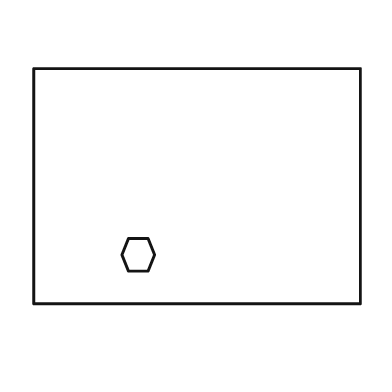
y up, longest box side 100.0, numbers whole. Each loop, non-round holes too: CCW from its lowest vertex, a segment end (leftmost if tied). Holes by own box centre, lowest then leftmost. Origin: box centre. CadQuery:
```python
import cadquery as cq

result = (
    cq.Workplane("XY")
    .moveTo(-50.0, -36.0)
    .lineTo(50.0, -36.0)
    .lineTo(50.0, 36.0)
    .lineTo(-50.0, 36.0)
    .close()
    .moveTo(-21.0, -26.0)
    .lineTo(-15.0, -26.0)
    .lineTo(-13.0, -21.0)
    .lineTo(-15.0, -16.0)
    .lineTo(-21.0, -16.0)
    .lineTo(-23.0, -21.0)
    .close()
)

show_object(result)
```